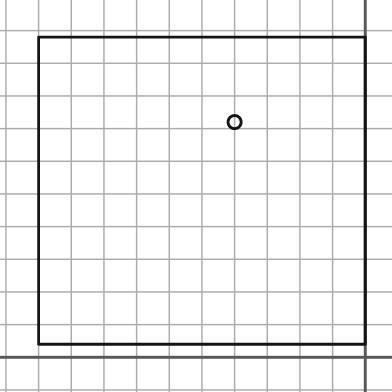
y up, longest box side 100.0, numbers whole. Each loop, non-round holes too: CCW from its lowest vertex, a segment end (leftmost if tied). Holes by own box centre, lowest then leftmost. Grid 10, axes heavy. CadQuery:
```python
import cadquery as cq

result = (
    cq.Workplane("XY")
    .moveTo(-100.0, 4.0)
    .lineTo(0.0, 4.0)
    .lineTo(0.0, 98.0)
    .lineTo(-100.0, 98.0)
    .close()
    .moveTo(-40.0, 72.0)
    .circle(2.0)
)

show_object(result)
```